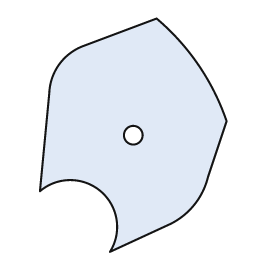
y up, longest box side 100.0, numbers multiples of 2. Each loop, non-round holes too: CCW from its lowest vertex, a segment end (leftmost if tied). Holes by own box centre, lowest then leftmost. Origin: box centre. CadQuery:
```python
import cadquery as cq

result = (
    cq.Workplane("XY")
    .moveTo(-10.0, -50.0)
    .lineTo(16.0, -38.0)
    .threePointArc((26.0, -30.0), (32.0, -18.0))
    .lineTo(40.0, 6.0)
    .threePointArc((28.0, 30.0), (10.0, 50.0))
    .lineTo(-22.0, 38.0)
    .threePointArc((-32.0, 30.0), (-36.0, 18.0))
    .lineTo(-40.0, -24.0)
    .threePointArc((-14.0, -24.0), (-10.0, -50.0))
    .close()
    .moveTo(0.0, 0.0)
    .circle(4.0)
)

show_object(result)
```